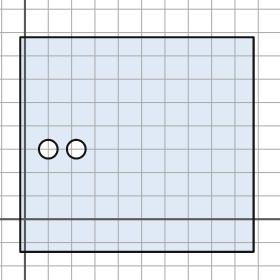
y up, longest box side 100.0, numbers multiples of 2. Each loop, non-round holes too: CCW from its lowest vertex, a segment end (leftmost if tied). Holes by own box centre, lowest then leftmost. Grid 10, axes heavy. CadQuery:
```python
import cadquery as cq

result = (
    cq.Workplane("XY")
    .moveTo(-2.0, -14.0)
    .lineTo(98.0, -14.0)
    .lineTo(98.0, 78.0)
    .lineTo(-2.0, 78.0)
    .close()
    .moveTo(10.0, 30.0)
    .circle(4.0)
    .moveTo(22.0, 30.0)
    .circle(4.0)
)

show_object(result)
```